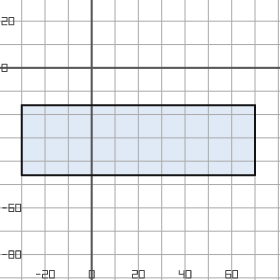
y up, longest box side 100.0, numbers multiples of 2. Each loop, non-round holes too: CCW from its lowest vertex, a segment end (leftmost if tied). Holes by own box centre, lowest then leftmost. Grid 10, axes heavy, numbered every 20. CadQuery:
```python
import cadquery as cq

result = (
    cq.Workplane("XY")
    .moveTo(-30.0, -46.0)
    .lineTo(70.0, -46.0)
    .lineTo(70.0, -16.0)
    .lineTo(-30.0, -16.0)
    .close()
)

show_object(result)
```